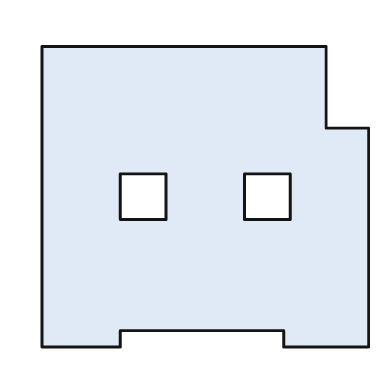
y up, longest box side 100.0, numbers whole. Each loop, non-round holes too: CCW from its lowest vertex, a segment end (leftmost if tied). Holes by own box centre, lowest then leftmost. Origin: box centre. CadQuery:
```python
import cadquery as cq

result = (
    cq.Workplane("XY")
    .moveTo(-50.0, -46.0)
    .lineTo(-26.0, -46.0)
    .lineTo(-26.0, -41.0)
    .lineTo(24.0, -41.0)
    .lineTo(24.0, -46.0)
    .lineTo(50.0, -46.0)
    .lineTo(50.0, 21.0)
    .lineTo(37.0, 21.0)
    .lineTo(37.0, 46.0)
    .lineTo(-50.0, 46.0)
    .close()
    .moveTo(-26.0, -7.0)
    .lineTo(-12.0, -7.0)
    .lineTo(-12.0, 7.0)
    .lineTo(-26.0, 7.0)
    .close()
    .moveTo(12.0, -7.0)
    .lineTo(26.0, -7.0)
    .lineTo(26.0, 7.0)
    .lineTo(12.0, 7.0)
    .close()
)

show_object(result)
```